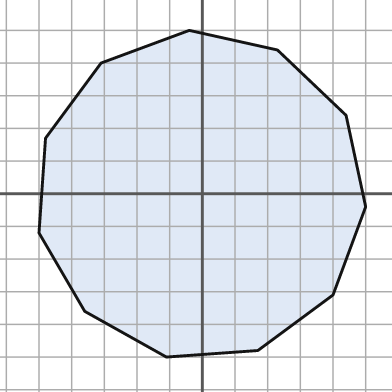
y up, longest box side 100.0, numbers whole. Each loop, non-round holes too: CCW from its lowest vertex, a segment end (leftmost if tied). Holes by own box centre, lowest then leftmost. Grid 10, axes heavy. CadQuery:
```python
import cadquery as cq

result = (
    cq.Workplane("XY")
    .moveTo(-11.0, -50.0)
    .lineTo(17.0, -48.0)
    .lineTo(40.0, -31.0)
    .lineTo(50.0, -4.0)
    .lineTo(44.0, 24.0)
    .lineTo(23.0, 44.0)
    .lineTo(-4.0, 50.0)
    .lineTo(-31.0, 40.0)
    .lineTo(-48.0, 17.0)
    .lineTo(-50.0, -12.0)
    .lineTo(-36.0, -36.0)
    .close()
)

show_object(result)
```